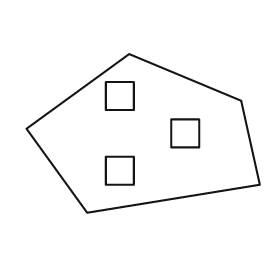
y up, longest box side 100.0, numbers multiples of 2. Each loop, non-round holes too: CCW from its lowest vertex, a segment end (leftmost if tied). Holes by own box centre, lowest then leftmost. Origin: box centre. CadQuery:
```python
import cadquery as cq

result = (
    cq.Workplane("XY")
    .moveTo(-24.0, -34.0)
    .lineTo(50.0, -22.0)
    .lineTo(42.0, 14.0)
    .lineTo(-6.0, 34.0)
    .lineTo(-50.0, 2.0)
    .close()
    .moveTo(-16.0, -22.0)
    .lineTo(-4.0, -22.0)
    .lineTo(-4.0, -10.0)
    .lineTo(-16.0, -10.0)
    .close()
    .moveTo(12.0, -6.0)
    .lineTo(24.0, -6.0)
    .lineTo(24.0, 6.0)
    .lineTo(12.0, 6.0)
    .close()
    .moveTo(-16.0, 10.0)
    .lineTo(-4.0, 10.0)
    .lineTo(-4.0, 22.0)
    .lineTo(-16.0, 22.0)
    .close()
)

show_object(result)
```